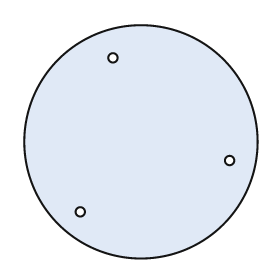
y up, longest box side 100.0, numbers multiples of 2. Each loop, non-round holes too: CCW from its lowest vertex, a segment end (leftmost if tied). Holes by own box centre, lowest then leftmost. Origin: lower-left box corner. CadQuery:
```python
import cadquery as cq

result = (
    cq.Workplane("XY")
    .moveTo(50.0, 50.0)
    .circle(50.0)
    .moveTo(24.0, 20.0)
    .circle(2.0)
    .moveTo(88.0, 42.0)
    .circle(2.0)
    .moveTo(38.0, 86.0)
    .circle(2.0)
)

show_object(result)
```